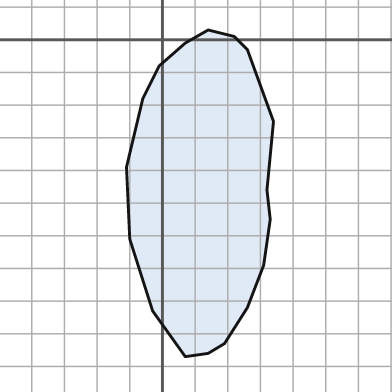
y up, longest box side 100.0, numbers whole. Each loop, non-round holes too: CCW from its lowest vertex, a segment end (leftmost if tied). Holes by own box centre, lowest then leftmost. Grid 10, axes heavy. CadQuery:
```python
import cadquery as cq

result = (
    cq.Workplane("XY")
    .moveTo(7.0, -97.0)
    .lineTo(14.0, -96.0)
    .lineTo(19.0, -93.0)
    .lineTo(26.0, -82.0)
    .lineTo(31.0, -69.0)
    .lineTo(33.0, -55.0)
    .lineTo(32.0, -46.0)
    .lineTo(34.0, -25.0)
    .lineTo(26.0, -3.0)
    .lineTo(22.0, 1.0)
    .lineTo(14.0, 3.0)
    .lineTo(7.0, -1.0)
    .lineTo(-1.0, -8.0)
    .lineTo(-6.0, -18.0)
    .lineTo(-11.0, -39.0)
    .lineTo(-10.0, -61.0)
    .lineTo(-3.0, -83.0)
    .close()
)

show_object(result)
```